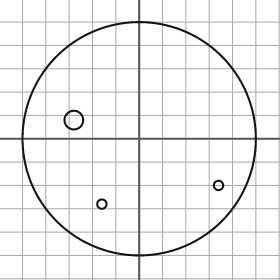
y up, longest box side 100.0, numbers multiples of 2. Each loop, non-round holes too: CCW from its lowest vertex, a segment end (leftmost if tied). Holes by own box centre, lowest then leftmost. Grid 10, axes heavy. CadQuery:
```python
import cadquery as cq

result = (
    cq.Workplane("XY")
    .moveTo(0.0, 0.0)
    .circle(50.0)
    .moveTo(-16.0, -28.0)
    .circle(2.0)
    .moveTo(34.0, -20.0)
    .circle(2.0)
    .moveTo(-28.0, 8.0)
    .circle(4.0)
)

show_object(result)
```